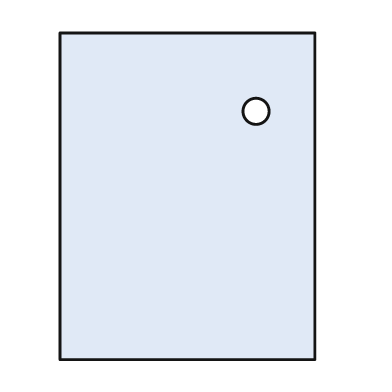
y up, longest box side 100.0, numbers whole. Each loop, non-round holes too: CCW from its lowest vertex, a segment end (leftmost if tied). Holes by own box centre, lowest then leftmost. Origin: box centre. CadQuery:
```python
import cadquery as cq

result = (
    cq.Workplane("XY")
    .moveTo(-39.0, -50.0)
    .lineTo(39.0, -50.0)
    .lineTo(39.0, 50.0)
    .lineTo(-39.0, 50.0)
    .close()
    .moveTo(21.0, 26.0)
    .circle(4.0)
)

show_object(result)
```